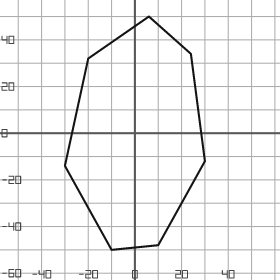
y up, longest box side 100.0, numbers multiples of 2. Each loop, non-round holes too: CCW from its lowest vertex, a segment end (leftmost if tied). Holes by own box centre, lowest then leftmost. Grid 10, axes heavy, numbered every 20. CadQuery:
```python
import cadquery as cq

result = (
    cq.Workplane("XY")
    .moveTo(-10.0, -50.0)
    .lineTo(10.0, -48.0)
    .lineTo(30.0, -12.0)
    .lineTo(24.0, 34.0)
    .lineTo(6.0, 50.0)
    .lineTo(-20.0, 32.0)
    .lineTo(-30.0, -14.0)
    .close()
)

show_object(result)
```